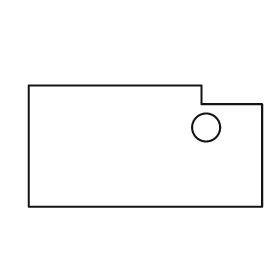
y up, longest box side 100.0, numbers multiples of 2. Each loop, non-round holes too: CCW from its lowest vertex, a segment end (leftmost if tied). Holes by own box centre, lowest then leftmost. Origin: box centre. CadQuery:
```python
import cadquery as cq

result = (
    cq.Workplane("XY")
    .moveTo(-50.0, -26.0)
    .lineTo(50.0, -26.0)
    .lineTo(50.0, 18.0)
    .lineTo(24.0, 18.0)
    .lineTo(24.0, 26.0)
    .lineTo(-50.0, 26.0)
    .close()
    .moveTo(26.0, 8.0)
    .circle(6.0)
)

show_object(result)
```